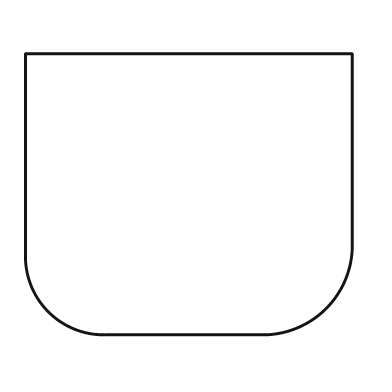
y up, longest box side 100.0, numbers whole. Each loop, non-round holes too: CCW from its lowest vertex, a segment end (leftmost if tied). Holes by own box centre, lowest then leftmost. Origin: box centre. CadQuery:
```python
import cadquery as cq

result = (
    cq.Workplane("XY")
    .moveTo(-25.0, -43.0)
    .lineTo(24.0, -43.0)
    .threePointArc((42.0, -35.0), (50.0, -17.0))
    .lineTo(50.0, 43.0)
    .lineTo(-50.0, 43.0)
    .lineTo(-50.0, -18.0)
    .threePointArc((-43.0, -36.0), (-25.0, -43.0))
    .close()
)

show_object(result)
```